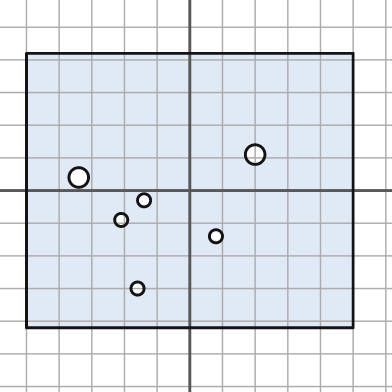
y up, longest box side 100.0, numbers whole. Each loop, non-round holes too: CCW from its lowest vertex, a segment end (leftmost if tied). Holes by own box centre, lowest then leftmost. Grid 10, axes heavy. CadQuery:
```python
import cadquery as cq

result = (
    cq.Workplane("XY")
    .moveTo(-50.0, -42.0)
    .lineTo(50.0, -42.0)
    .lineTo(50.0, 42.0)
    .lineTo(-50.0, 42.0)
    .close()
    .moveTo(-16.0, -30.0)
    .circle(2.0)
    .moveTo(8.0, -14.0)
    .circle(2.0)
    .moveTo(-21.0, -9.0)
    .circle(2.0)
    .moveTo(-14.0, -3.0)
    .circle(2.0)
    .moveTo(-34.0, 4.0)
    .circle(3.0)
    .moveTo(20.0, 11.0)
    .circle(3.0)
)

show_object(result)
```